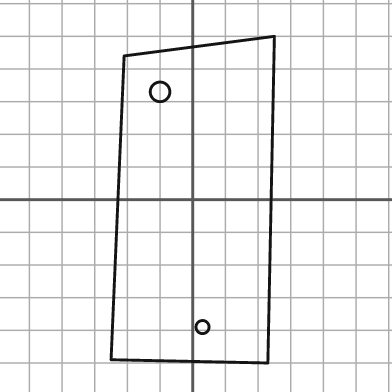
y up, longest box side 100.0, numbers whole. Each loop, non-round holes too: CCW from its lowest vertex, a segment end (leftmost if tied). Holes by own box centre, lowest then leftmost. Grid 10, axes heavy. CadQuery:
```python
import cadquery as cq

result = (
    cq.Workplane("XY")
    .moveTo(23.0, -50.0)
    .lineTo(25.0, 50.0)
    .lineTo(-21.0, 44.0)
    .lineTo(-25.0, -49.0)
    .close()
    .moveTo(3.0, -39.0)
    .circle(2.0)
    .moveTo(-10.0, 33.0)
    .circle(3.0)
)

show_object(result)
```